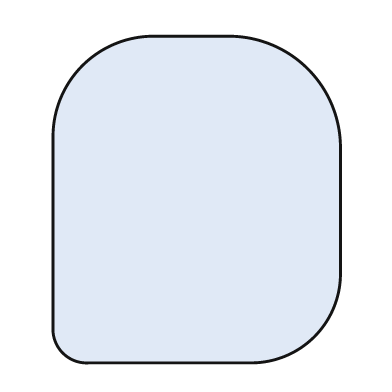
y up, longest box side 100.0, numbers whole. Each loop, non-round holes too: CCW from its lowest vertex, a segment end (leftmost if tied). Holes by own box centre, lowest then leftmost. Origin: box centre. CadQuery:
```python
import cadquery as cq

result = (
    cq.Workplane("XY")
    .moveTo(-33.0, -50.0)
    .lineTo(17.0, -50.0)
    .threePointArc((36.0, -42.0), (44.0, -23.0))
    .lineTo(44.0, 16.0)
    .threePointArc((34.0, 40.0), (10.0, 50.0))
    .lineTo(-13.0, 50.0)
    .threePointArc((-35.0, 41.0), (-44.0, 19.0))
    .lineTo(-44.0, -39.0)
    .threePointArc((-41.0, -47.0), (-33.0, -50.0))
    .close()
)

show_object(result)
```